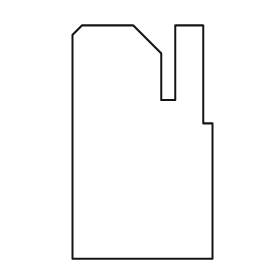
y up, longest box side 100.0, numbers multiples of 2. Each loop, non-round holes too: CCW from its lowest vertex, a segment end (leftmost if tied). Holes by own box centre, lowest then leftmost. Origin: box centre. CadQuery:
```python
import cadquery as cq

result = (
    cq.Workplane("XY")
    .moveTo(-30.0, -50.0)
    .lineTo(30.0, -50.0)
    .lineTo(30.0, 8.0)
    .lineTo(26.0, 8.0)
    .lineTo(26.0, 50.0)
    .lineTo(14.0, 50.0)
    .lineTo(14.0, 18.0)
    .lineTo(8.0, 18.0)
    .lineTo(8.0, 38.0)
    .lineTo(-4.0, 50.0)
    .lineTo(-26.0, 50.0)
    .lineTo(-30.0, 46.0)
    .close()
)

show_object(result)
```